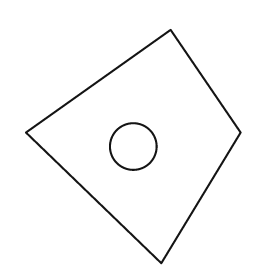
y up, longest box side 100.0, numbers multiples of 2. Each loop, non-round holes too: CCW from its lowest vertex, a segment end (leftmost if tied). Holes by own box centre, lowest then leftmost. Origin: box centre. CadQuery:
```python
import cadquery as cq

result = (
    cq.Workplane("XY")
    .moveTo(12.0, -50.0)
    .lineTo(46.0, 6.0)
    .lineTo(16.0, 50.0)
    .lineTo(-46.0, 6.0)
    .close()
    .moveTo(0.0, 0.0)
    .circle(10.0)
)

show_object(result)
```